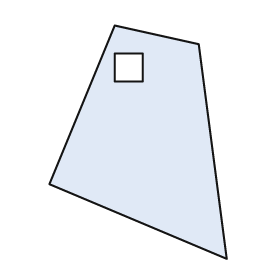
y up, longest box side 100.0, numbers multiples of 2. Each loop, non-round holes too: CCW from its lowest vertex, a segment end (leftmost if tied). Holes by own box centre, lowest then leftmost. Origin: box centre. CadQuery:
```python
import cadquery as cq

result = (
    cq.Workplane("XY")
    .moveTo(38.0, -50.0)
    .lineTo(26.0, 42.0)
    .lineTo(-10.0, 50.0)
    .lineTo(-38.0, -18.0)
    .close()
    .moveTo(-10.0, 26.0)
    .lineTo(2.0, 26.0)
    .lineTo(2.0, 38.0)
    .lineTo(-10.0, 38.0)
    .close()
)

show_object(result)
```